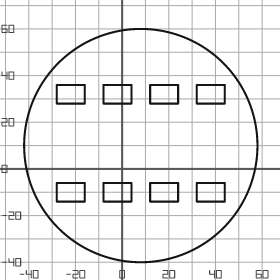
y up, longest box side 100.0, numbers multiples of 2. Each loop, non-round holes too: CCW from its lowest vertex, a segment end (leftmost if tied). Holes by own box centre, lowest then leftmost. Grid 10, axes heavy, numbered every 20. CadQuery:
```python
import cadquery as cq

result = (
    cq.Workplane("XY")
    .moveTo(8.0, 10.0)
    .circle(50.0)
    .moveTo(-28.0, -14.0)
    .lineTo(-16.0, -14.0)
    .lineTo(-16.0, -6.0)
    .lineTo(-28.0, -6.0)
    .close()
    .moveTo(-8.0, -14.0)
    .lineTo(4.0, -14.0)
    .lineTo(4.0, -6.0)
    .lineTo(-8.0, -6.0)
    .close()
    .moveTo(12.0, -14.0)
    .lineTo(24.0, -14.0)
    .lineTo(24.0, -6.0)
    .lineTo(12.0, -6.0)
    .close()
    .moveTo(32.0, -14.0)
    .lineTo(44.0, -14.0)
    .lineTo(44.0, -6.0)
    .lineTo(32.0, -6.0)
    .close()
    .moveTo(-28.0, 28.0)
    .lineTo(-16.0, 28.0)
    .lineTo(-16.0, 36.0)
    .lineTo(-28.0, 36.0)
    .close()
    .moveTo(-8.0, 28.0)
    .lineTo(4.0, 28.0)
    .lineTo(4.0, 36.0)
    .lineTo(-8.0, 36.0)
    .close()
    .moveTo(12.0, 28.0)
    .lineTo(24.0, 28.0)
    .lineTo(24.0, 36.0)
    .lineTo(12.0, 36.0)
    .close()
    .moveTo(32.0, 28.0)
    .lineTo(44.0, 28.0)
    .lineTo(44.0, 36.0)
    .lineTo(32.0, 36.0)
    .close()
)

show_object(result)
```